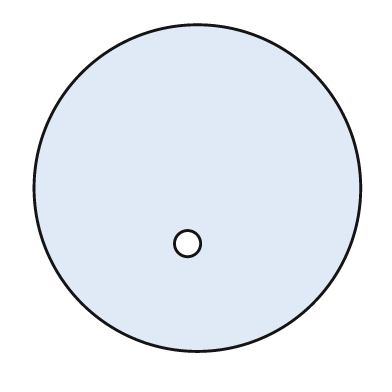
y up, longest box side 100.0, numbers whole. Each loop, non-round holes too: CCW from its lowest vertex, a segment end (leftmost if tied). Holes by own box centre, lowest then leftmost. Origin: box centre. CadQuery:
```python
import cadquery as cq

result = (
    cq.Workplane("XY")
    .moveTo(0.0, 0.0)
    .circle(50.0)
    .moveTo(-3.0, -17.0)
    .circle(4.0)
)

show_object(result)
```